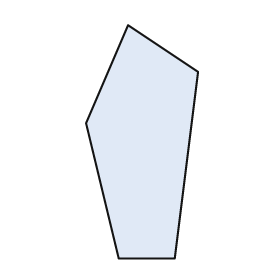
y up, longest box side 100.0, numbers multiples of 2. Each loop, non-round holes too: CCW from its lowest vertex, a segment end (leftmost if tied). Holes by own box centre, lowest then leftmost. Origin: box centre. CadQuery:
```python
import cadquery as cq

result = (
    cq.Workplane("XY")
    .moveTo(-10.0, -50.0)
    .lineTo(14.0, -50.0)
    .lineTo(24.0, 30.0)
    .lineTo(-6.0, 50.0)
    .lineTo(-24.0, 8.0)
    .close()
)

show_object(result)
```